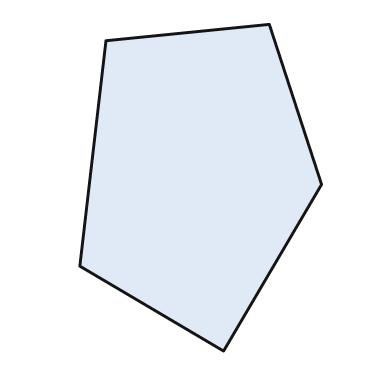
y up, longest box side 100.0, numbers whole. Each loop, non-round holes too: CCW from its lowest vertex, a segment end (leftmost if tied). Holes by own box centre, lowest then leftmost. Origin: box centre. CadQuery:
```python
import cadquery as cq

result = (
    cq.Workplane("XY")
    .moveTo(7.0, -50.0)
    .lineTo(37.0, 1.0)
    .lineTo(21.0, 50.0)
    .lineTo(-29.0, 45.0)
    .lineTo(-37.0, -24.0)
    .close()
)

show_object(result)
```